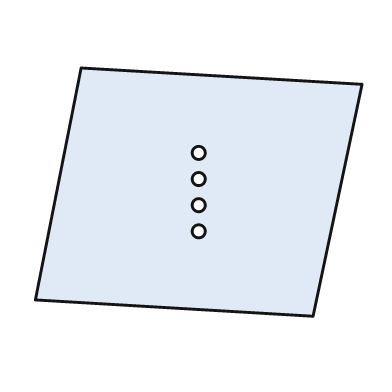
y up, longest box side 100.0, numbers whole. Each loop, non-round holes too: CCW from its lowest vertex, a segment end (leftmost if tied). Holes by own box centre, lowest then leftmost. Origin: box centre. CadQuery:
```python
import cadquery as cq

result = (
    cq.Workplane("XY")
    .moveTo(35.0, -38.0)
    .lineTo(50.0, 33.0)
    .lineTo(-36.0, 38.0)
    .lineTo(-50.0, -33.0)
    .close()
    .moveTo(0.0, -12.0)
    .circle(2.0)
    .moveTo(0.0, -4.0)
    .circle(2.0)
    .moveTo(0.0, 4.0)
    .circle(2.0)
    .moveTo(0.0, 12.0)
    .circle(2.0)
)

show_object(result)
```